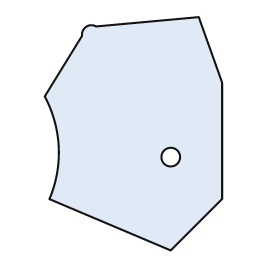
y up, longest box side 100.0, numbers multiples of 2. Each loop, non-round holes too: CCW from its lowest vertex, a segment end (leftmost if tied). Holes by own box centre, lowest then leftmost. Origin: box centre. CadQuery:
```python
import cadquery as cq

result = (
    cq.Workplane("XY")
    .moveTo(16.0, -50.0)
    .lineTo(38.0, -28.0)
    .lineTo(38.0, 22.0)
    .lineTo(28.0, 50.0)
    .lineTo(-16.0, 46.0)
    .threePointArc((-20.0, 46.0), (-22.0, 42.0))
    .lineTo(-38.0, 16.0)
    .threePointArc((-32.0, -6.0), (-36.0, -28.0))
    .close()
    .moveTo(16.0, -10.0)
    .circle(4.0)
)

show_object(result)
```